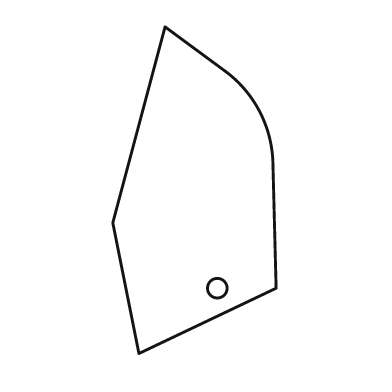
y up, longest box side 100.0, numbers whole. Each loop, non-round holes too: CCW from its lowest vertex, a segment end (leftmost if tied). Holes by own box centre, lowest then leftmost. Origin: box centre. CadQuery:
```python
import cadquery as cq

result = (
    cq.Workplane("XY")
    .moveTo(-17.0, -50.0)
    .lineTo(25.0, -30.0)
    .lineTo(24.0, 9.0)
    .threePointArc((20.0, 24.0), (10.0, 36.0))
    .lineTo(-9.0, 50.0)
    .lineTo(-25.0, -10.0)
    .close()
    .moveTo(7.0, -30.0)
    .circle(3.0)
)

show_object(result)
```